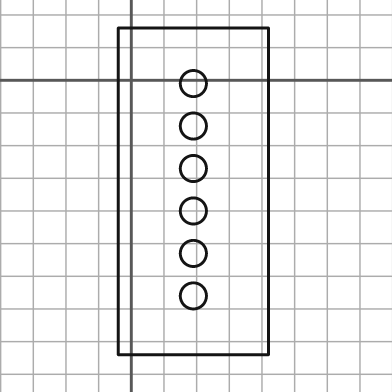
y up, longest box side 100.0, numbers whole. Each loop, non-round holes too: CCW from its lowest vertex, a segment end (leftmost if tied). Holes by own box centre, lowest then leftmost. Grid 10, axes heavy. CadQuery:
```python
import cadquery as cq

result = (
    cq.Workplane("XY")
    .moveTo(-4.0, -84.0)
    .lineTo(42.0, -84.0)
    .lineTo(42.0, 16.0)
    .lineTo(-4.0, 16.0)
    .close()
    .moveTo(19.0, -66.0)
    .circle(4.0)
    .moveTo(19.0, -53.0)
    .circle(4.0)
    .moveTo(19.0, -40.0)
    .circle(4.0)
    .moveTo(19.0, -27.0)
    .circle(4.0)
    .moveTo(19.0, -14.0)
    .circle(4.0)
    .moveTo(19.0, -1.0)
    .circle(4.0)
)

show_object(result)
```